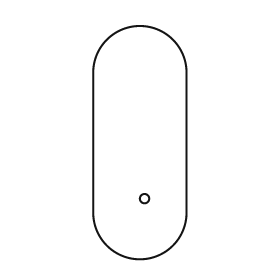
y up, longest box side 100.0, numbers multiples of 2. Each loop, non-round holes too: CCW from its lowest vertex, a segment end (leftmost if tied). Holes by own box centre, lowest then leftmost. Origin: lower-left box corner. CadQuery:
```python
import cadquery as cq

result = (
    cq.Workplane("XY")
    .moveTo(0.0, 20.0)
    .threePointArc((20.0, 0.0), (40.0, 20.0))
    .lineTo(40.0, 80.0)
    .threePointArc((20.0, 100.0), (0.0, 80.0))
    .close()
    .moveTo(22.0, 26.0)
    .circle(2.0)
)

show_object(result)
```